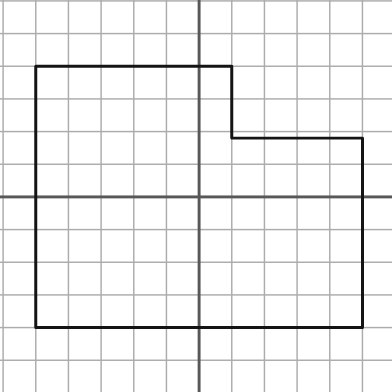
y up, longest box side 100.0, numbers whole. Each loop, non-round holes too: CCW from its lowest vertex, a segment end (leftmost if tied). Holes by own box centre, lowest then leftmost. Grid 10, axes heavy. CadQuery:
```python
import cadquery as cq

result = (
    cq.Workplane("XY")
    .moveTo(-50.0, -40.0)
    .lineTo(50.0, -40.0)
    .lineTo(50.0, 18.0)
    .lineTo(10.0, 18.0)
    .lineTo(10.0, 40.0)
    .lineTo(-50.0, 40.0)
    .close()
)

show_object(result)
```